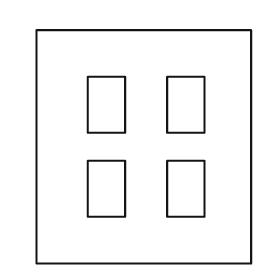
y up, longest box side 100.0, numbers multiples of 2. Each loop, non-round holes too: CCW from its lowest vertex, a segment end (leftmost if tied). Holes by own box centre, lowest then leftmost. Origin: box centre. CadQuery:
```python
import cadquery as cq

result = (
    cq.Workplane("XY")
    .moveTo(-46.0, -50.0)
    .lineTo(46.0, -50.0)
    .lineTo(46.0, 50.0)
    .lineTo(-46.0, 50.0)
    .close()
    .moveTo(-24.0, -30.0)
    .lineTo(-8.0, -30.0)
    .lineTo(-8.0, -6.0)
    .lineTo(-24.0, -6.0)
    .close()
    .moveTo(10.0, -30.0)
    .lineTo(26.0, -30.0)
    .lineTo(26.0, -6.0)
    .lineTo(10.0, -6.0)
    .close()
    .moveTo(-24.0, 6.0)
    .lineTo(-8.0, 6.0)
    .lineTo(-8.0, 30.0)
    .lineTo(-24.0, 30.0)
    .close()
    .moveTo(10.0, 6.0)
    .lineTo(26.0, 6.0)
    .lineTo(26.0, 30.0)
    .lineTo(10.0, 30.0)
    .close()
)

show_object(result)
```